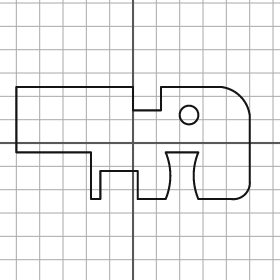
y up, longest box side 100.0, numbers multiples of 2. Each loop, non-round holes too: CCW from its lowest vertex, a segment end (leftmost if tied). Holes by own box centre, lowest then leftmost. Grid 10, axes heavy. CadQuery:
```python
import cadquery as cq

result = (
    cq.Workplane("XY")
    .moveTo(-18.0, -24.0)
    .lineTo(-14.0, -24.0)
    .lineTo(-14.0, -12.0)
    .lineTo(2.0, -12.0)
    .lineTo(2.0, -24.0)
    .lineTo(14.0, -24.0)
    .threePointArc((16.0, -14.0), (14.0, -4.0))
    .lineTo(28.0, -4.0)
    .threePointArc((26.0, -14.0), (28.0, -24.0))
    .lineTo(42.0, -24.0)
    .threePointArc((48.0, -22.0), (50.0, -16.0))
    .lineTo(50.0, 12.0)
    .threePointArc((46.0, 20.0), (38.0, 24.0))
    .lineTo(12.0, 24.0)
    .lineTo(12.0, 14.0)
    .lineTo(0.0, 14.0)
    .lineTo(0.0, 24.0)
    .lineTo(-50.0, 24.0)
    .lineTo(-50.0, -4.0)
    .lineTo(-18.0, -4.0)
    .close()
    .moveTo(24.0, 12.0)
    .circle(4.0)
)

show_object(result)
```